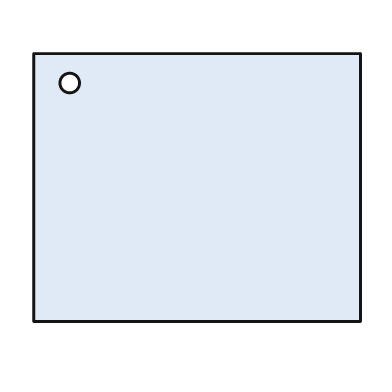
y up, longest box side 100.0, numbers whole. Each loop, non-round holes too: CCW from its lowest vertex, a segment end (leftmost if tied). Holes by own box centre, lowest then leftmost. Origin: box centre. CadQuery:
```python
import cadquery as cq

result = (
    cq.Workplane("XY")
    .moveTo(-50.0, -41.0)
    .lineTo(50.0, -41.0)
    .lineTo(50.0, 41.0)
    .lineTo(-50.0, 41.0)
    .close()
    .moveTo(-39.0, 32.0)
    .circle(3.0)
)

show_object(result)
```